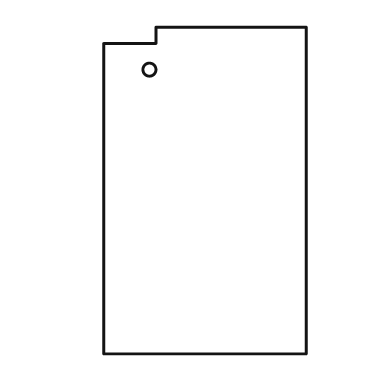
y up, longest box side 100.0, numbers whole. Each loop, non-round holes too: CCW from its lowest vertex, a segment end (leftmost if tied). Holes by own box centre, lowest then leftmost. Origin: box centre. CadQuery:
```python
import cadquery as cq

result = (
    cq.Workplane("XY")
    .moveTo(-31.0, -50.0)
    .lineTo(31.0, -50.0)
    .lineTo(31.0, 50.0)
    .lineTo(-15.0, 50.0)
    .lineTo(-15.0, 45.0)
    .lineTo(-31.0, 45.0)
    .close()
    .moveTo(-17.0, 37.0)
    .circle(2.0)
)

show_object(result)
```